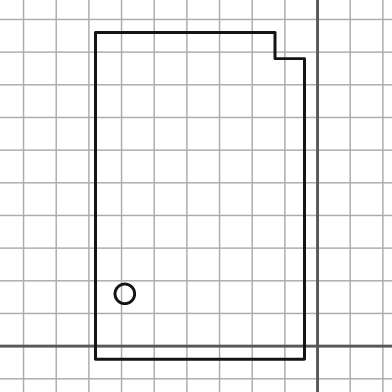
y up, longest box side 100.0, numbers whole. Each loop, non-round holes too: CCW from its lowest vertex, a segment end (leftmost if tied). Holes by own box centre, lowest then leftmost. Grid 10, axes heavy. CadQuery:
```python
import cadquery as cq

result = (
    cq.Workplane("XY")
    .moveTo(-68.0, -4.0)
    .lineTo(-4.0, -4.0)
    .lineTo(-4.0, 88.0)
    .lineTo(-13.0, 88.0)
    .lineTo(-13.0, 96.0)
    .lineTo(-68.0, 96.0)
    .close()
    .moveTo(-59.0, 16.0)
    .circle(3.0)
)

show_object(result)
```